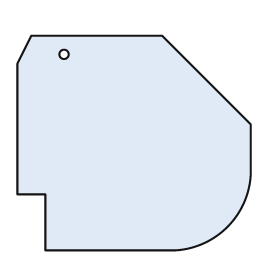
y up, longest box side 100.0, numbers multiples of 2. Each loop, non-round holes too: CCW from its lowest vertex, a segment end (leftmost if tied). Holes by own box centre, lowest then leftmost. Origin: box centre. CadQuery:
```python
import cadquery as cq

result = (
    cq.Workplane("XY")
    .moveTo(-38.0, -46.0)
    .lineTo(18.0, -46.0)
    .threePointArc((40.0, -36.0), (50.0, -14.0))
    .lineTo(50.0, 8.0)
    .lineTo(12.0, 46.0)
    .lineTo(-44.0, 46.0)
    .lineTo(-50.0, 34.0)
    .lineTo(-50.0, -22.0)
    .lineTo(-38.0, -22.0)
    .close()
    .moveTo(-30.0, 38.0)
    .circle(2.0)
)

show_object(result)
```